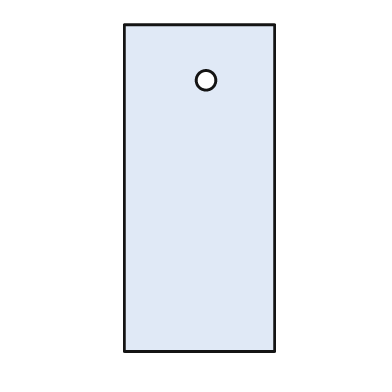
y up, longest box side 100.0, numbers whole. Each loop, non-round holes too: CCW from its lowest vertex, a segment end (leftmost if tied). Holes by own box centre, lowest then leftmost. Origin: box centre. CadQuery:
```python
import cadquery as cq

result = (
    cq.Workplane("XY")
    .moveTo(-23.0, -50.0)
    .lineTo(23.0, -50.0)
    .lineTo(23.0, 50.0)
    .lineTo(-23.0, 50.0)
    .close()
    .moveTo(2.0, 33.0)
    .circle(3.0)
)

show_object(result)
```